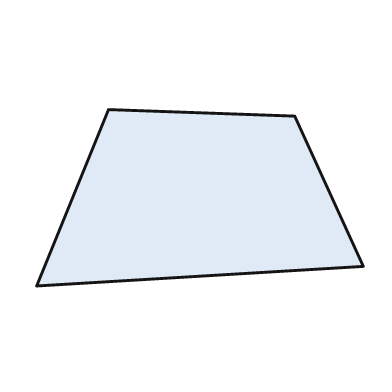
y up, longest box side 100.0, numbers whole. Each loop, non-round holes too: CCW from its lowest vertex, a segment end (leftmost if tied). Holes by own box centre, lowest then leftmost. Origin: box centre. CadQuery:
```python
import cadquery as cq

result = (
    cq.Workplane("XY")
    .moveTo(-50.0, -27.0)
    .lineTo(50.0, -21.0)
    .lineTo(29.0, 25.0)
    .lineTo(-28.0, 27.0)
    .close()
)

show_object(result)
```